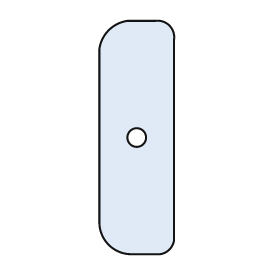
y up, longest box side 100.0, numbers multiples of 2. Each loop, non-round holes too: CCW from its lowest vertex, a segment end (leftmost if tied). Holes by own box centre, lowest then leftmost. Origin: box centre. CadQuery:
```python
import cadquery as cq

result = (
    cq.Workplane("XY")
    .moveTo(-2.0, -50.0)
    .lineTo(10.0, -50.0)
    .threePointArc((14.0, -48.0), (16.0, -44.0))
    .lineTo(16.0, 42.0)
    .threePointArc((14.0, 48.0), (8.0, 50.0))
    .lineTo(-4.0, 50.0)
    .threePointArc((-12.0, 46.0), (-16.0, 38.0))
    .lineTo(-16.0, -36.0)
    .threePointArc((-12.0, -46.0), (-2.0, -50.0))
    .close()
    .moveTo(0.0, 0.0)
    .circle(4.0)
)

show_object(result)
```